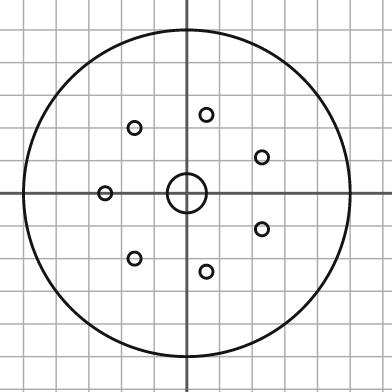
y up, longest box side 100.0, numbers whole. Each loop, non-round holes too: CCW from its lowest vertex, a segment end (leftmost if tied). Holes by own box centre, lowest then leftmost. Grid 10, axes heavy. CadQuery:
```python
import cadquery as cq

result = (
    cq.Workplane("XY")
    .moveTo(0.0, 0.0)
    .circle(50.0)
    .moveTo(6.0, -24.0)
    .circle(2.0)
    .moveTo(-16.0, -20.0)
    .circle(2.0)
    .moveTo(23.0, -11.0)
    .circle(2.0)
    .moveTo(-25.0, 0.0)
    .circle(2.0)
    .moveTo(0.0, 0.0)
    .circle(6.0)
    .moveTo(23.0, 11.0)
    .circle(2.0)
    .moveTo(-16.0, 20.0)
    .circle(2.0)
    .moveTo(6.0, 24.0)
    .circle(2.0)
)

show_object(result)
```